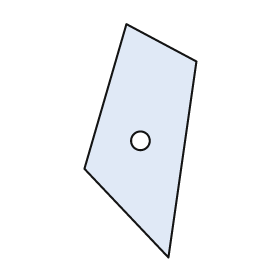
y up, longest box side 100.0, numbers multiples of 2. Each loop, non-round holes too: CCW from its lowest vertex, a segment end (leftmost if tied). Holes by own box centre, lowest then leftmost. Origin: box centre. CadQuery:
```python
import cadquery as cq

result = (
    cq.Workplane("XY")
    .moveTo(12.0, -50.0)
    .lineTo(24.0, 34.0)
    .lineTo(-6.0, 50.0)
    .lineTo(-24.0, -12.0)
    .close()
    .moveTo(0.0, 0.0)
    .circle(4.0)
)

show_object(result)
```